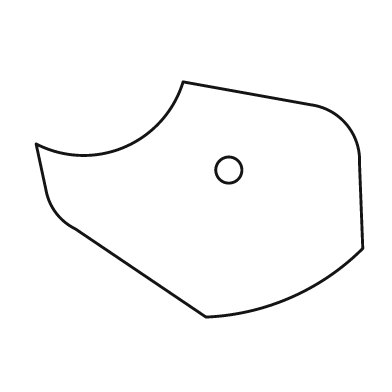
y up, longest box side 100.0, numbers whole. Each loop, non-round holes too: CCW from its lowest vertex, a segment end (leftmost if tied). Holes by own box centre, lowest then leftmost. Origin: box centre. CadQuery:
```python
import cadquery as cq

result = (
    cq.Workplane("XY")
    .moveTo(2.0, -36.0)
    .threePointArc((28.0, -30.0), (50.0, -15.0))
    .lineTo(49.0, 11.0)
    .threePointArc((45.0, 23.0), (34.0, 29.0))
    .lineTo(-5.0, 36.0)
    .threePointArc((-23.0, 16.0), (-50.0, 17.0))
    .lineTo(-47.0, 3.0)
    .threePointArc((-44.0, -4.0), (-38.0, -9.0))
    .close()
    .moveTo(9.0, 9.0)
    .circle(4.0)
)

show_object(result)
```